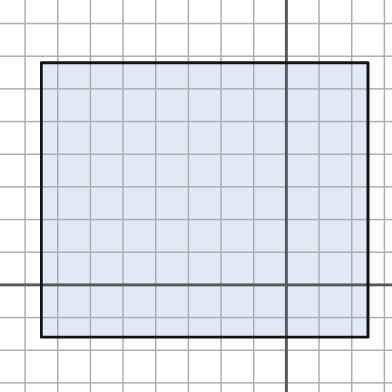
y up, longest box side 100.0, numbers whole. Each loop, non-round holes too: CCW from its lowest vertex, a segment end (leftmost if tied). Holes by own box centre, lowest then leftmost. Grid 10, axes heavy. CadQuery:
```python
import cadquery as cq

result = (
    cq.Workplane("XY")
    .moveTo(-75.0, -16.0)
    .lineTo(25.0, -16.0)
    .lineTo(25.0, 68.0)
    .lineTo(-75.0, 68.0)
    .close()
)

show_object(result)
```